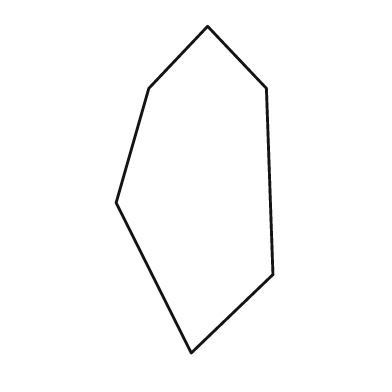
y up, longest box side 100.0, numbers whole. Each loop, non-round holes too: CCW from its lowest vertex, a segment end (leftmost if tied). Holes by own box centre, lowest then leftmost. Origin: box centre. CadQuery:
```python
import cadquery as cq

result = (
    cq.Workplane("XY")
    .moveTo(-1.0, -50.0)
    .lineTo(24.0, -26.0)
    .lineTo(22.0, 31.0)
    .lineTo(4.0, 50.0)
    .lineTo(-14.0, 31.0)
    .lineTo(-24.0, -4.0)
    .close()
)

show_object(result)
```